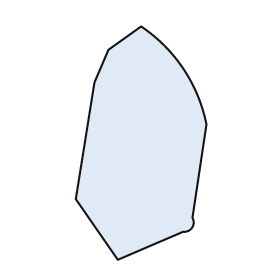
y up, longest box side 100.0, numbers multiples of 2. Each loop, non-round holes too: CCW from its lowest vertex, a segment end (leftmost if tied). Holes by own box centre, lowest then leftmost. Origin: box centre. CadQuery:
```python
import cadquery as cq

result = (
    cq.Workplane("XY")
    .moveTo(-10.0, -50.0)
    .lineTo(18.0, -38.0)
    .threePointArc((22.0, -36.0), (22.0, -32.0))
    .lineTo(28.0, 8.0)
    .threePointArc((18.0, 32.0), (0.0, 50.0))
    .lineTo(-14.0, 40.0)
    .lineTo(-20.0, 26.0)
    .lineTo(-28.0, -24.0)
    .close()
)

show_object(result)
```